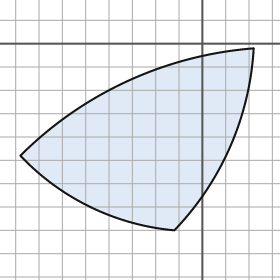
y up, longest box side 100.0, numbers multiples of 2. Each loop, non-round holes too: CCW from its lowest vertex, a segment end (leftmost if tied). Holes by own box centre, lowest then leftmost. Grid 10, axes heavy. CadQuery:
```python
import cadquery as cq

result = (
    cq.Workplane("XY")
    .moveTo(-12.0, -80.0)
    .threePointArc((12.0, -44.0), (22.0, -2.0))
    .threePointArc((-32.0, -16.0), (-78.0, -48.0))
    .threePointArc((-48.0, -70.0), (-12.0, -80.0))
    .close()
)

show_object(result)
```